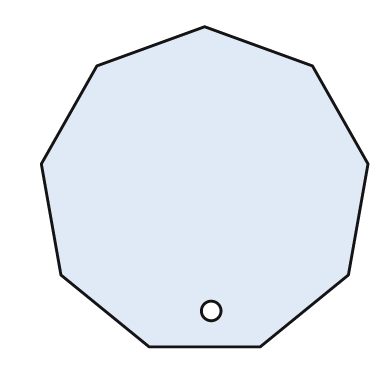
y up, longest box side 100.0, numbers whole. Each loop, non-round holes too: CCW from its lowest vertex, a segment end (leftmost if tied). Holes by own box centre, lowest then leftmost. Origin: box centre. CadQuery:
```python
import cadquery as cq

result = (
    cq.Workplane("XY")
    .moveTo(-17.0, -49.0)
    .lineTo(17.0, -49.0)
    .lineTo(44.0, -27.0)
    .lineTo(50.0, 7.0)
    .lineTo(33.0, 37.0)
    .lineTo(0.0, 49.0)
    .lineTo(-33.0, 37.0)
    .lineTo(-50.0, 7.0)
    .lineTo(-44.0, -27.0)
    .close()
    .moveTo(2.0, -38.0)
    .circle(3.0)
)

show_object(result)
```